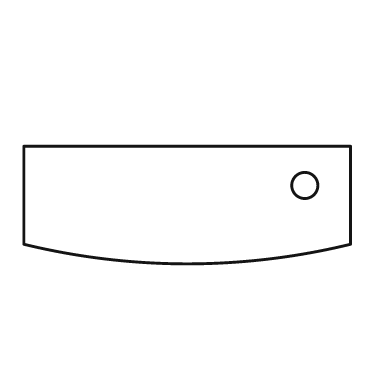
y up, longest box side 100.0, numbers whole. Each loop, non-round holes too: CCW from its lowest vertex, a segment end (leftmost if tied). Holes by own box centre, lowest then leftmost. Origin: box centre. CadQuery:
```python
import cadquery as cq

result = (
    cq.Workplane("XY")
    .moveTo(-50.0, -12.0)
    .threePointArc((0.0, -18.0), (50.0, -12.0))
    .lineTo(50.0, 18.0)
    .lineTo(-50.0, 18.0)
    .close()
    .moveTo(36.0, 6.0)
    .circle(4.0)
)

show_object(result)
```